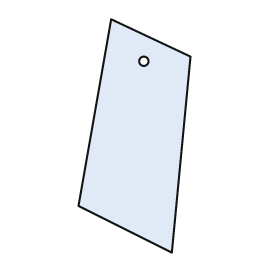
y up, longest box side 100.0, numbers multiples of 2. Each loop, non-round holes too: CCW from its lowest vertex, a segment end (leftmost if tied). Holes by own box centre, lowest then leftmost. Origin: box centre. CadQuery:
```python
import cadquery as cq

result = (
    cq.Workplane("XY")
    .moveTo(16.0, -50.0)
    .lineTo(24.0, 34.0)
    .lineTo(-10.0, 50.0)
    .lineTo(-24.0, -30.0)
    .close()
    .moveTo(4.0, 32.0)
    .circle(2.0)
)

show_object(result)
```